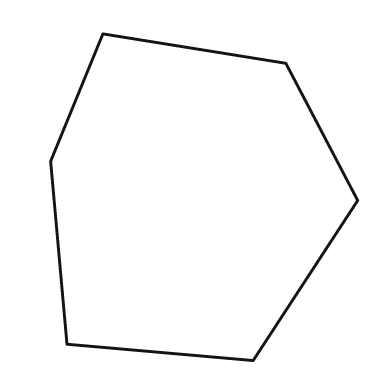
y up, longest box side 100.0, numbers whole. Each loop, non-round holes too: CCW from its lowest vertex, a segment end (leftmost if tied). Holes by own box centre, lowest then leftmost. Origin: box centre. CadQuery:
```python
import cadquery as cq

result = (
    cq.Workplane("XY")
    .moveTo(15.0, -50.0)
    .lineTo(47.0, -1.0)
    .lineTo(25.0, 41.0)
    .lineTo(-31.0, 50.0)
    .lineTo(-47.0, 11.0)
    .lineTo(-42.0, -45.0)
    .close()
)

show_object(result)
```